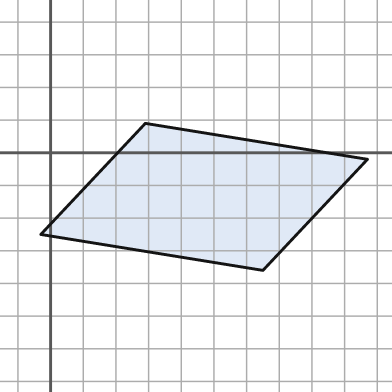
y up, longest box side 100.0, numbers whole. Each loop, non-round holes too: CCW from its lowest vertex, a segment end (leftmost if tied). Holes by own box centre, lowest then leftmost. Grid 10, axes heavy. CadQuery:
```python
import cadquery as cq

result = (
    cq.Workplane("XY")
    .moveTo(65.0, -36.0)
    .lineTo(97.0, -2.0)
    .lineTo(29.0, 9.0)
    .lineTo(-3.0, -25.0)
    .close()
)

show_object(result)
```